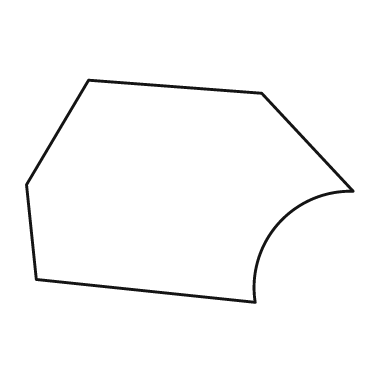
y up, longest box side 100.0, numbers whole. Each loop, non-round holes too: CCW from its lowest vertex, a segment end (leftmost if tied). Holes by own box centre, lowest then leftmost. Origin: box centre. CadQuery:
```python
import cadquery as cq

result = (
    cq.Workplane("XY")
    .moveTo(20.0, -34.0)
    .threePointArc((27.0, -10.0), (50.0, 0.0))
    .lineTo(22.0, 30.0)
    .lineTo(-31.0, 34.0)
    .lineTo(-50.0, 2.0)
    .lineTo(-47.0, -27.0)
    .close()
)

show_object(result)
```